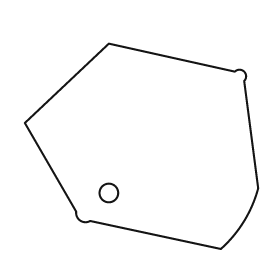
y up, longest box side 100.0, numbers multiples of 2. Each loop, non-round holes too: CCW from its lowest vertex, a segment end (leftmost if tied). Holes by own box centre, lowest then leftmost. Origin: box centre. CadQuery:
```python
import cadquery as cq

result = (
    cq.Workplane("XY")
    .moveTo(34.0, -44.0)
    .threePointArc((44.0, -32.0), (50.0, -18.0))
    .lineTo(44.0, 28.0)
    .threePointArc((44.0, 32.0), (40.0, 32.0))
    .lineTo(-14.0, 44.0)
    .lineTo(-50.0, 10.0)
    .lineTo(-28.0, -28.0)
    .threePointArc((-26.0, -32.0), (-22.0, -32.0))
    .close()
    .moveTo(-14.0, -20.0)
    .circle(4.0)
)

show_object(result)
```